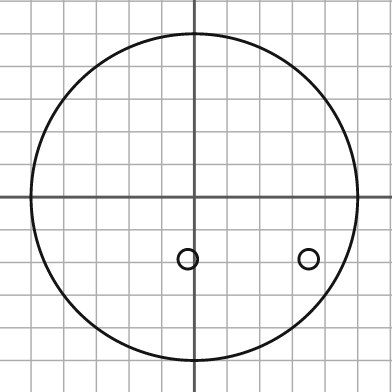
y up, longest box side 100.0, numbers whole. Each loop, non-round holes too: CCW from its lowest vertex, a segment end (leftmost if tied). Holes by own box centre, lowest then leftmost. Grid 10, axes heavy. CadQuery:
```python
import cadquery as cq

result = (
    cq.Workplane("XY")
    .moveTo(0.0, 0.0)
    .circle(50.0)
    .moveTo(-2.0, -19.0)
    .circle(3.0)
    .moveTo(35.0, -19.0)
    .circle(3.0)
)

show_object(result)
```